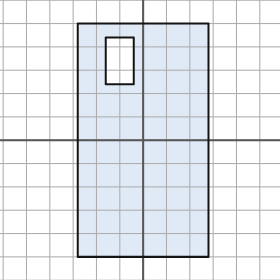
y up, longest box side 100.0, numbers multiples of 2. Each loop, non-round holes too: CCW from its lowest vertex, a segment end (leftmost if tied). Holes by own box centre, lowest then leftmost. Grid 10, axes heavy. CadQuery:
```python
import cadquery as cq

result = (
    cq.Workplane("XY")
    .moveTo(-28.0, -50.0)
    .lineTo(28.0, -50.0)
    .lineTo(28.0, 50.0)
    .lineTo(-28.0, 50.0)
    .close()
    .moveTo(-16.0, 24.0)
    .lineTo(-4.0, 24.0)
    .lineTo(-4.0, 44.0)
    .lineTo(-16.0, 44.0)
    .close()
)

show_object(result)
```